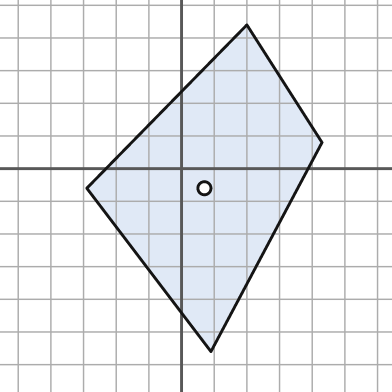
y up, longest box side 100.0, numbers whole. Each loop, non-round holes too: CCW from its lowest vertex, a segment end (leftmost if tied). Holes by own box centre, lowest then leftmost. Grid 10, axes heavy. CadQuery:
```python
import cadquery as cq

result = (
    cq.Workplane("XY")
    .moveTo(9.0, -56.0)
    .lineTo(43.0, 8.0)
    .lineTo(20.0, 44.0)
    .lineTo(-29.0, -6.0)
    .close()
    .moveTo(7.0, -6.0)
    .circle(2.0)
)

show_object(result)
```